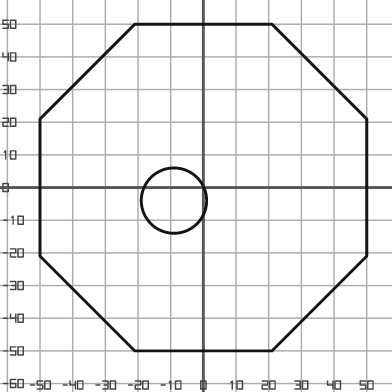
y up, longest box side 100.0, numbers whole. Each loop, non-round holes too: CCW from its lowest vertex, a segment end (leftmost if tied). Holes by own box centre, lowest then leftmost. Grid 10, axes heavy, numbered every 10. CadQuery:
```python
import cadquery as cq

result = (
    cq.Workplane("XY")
    .moveTo(-21.0, -50.0)
    .lineTo(21.0, -50.0)
    .lineTo(50.0, -21.0)
    .lineTo(50.0, 21.0)
    .lineTo(21.0, 50.0)
    .lineTo(-21.0, 50.0)
    .lineTo(-50.0, 21.0)
    .lineTo(-50.0, -21.0)
    .close()
    .moveTo(-9.0, -4.0)
    .circle(10.0)
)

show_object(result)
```